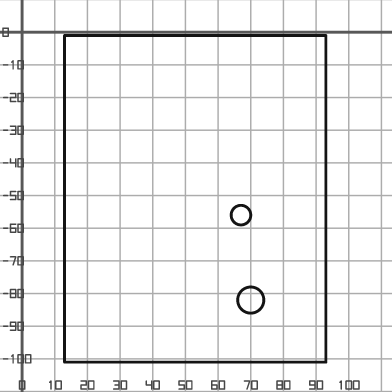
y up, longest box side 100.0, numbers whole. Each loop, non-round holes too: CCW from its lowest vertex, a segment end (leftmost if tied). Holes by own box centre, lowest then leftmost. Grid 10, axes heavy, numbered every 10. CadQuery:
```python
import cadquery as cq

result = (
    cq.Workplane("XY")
    .moveTo(13.0, -101.0)
    .lineTo(93.0, -101.0)
    .lineTo(93.0, -1.0)
    .lineTo(13.0, -1.0)
    .close()
    .moveTo(70.0, -82.0)
    .circle(4.0)
    .moveTo(67.0, -56.0)
    .circle(3.0)
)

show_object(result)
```